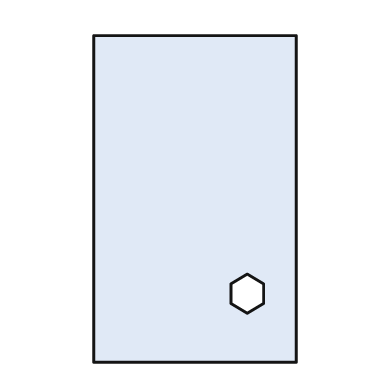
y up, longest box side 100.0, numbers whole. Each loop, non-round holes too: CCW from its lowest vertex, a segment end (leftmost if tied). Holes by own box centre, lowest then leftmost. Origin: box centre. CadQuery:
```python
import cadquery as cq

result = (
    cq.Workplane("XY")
    .moveTo(-31.0, -50.0)
    .lineTo(31.0, -50.0)
    .lineTo(31.0, 50.0)
    .lineTo(-31.0, 50.0)
    .close()
    .moveTo(16.0, -35.0)
    .lineTo(21.0, -32.0)
    .lineTo(21.0, -26.0)
    .lineTo(16.0, -23.0)
    .lineTo(11.0, -26.0)
    .lineTo(11.0, -32.0)
    .close()
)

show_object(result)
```